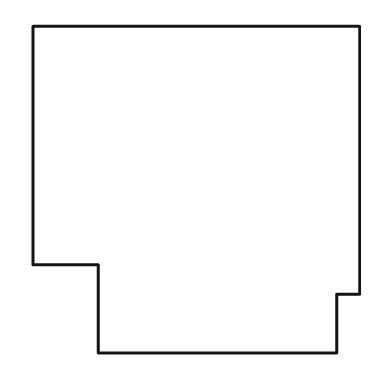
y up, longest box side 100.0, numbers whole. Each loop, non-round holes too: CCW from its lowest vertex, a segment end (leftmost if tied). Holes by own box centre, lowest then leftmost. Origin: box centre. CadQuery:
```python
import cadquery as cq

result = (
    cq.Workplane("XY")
    .moveTo(-30.0, -50.0)
    .lineTo(43.0, -50.0)
    .lineTo(43.0, -32.0)
    .lineTo(50.0, -32.0)
    .lineTo(50.0, 50.0)
    .lineTo(-50.0, 50.0)
    .lineTo(-50.0, -23.0)
    .lineTo(-30.0, -23.0)
    .close()
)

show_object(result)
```